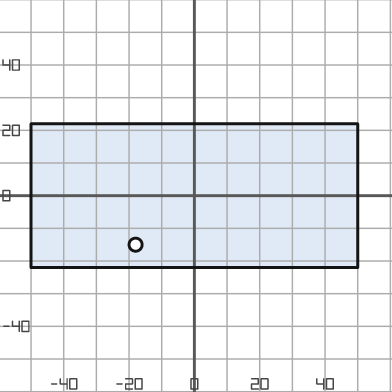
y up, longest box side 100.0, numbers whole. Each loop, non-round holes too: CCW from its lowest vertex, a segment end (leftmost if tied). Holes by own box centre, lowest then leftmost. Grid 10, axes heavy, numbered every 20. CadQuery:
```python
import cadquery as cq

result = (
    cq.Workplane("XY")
    .moveTo(-50.0, -22.0)
    .lineTo(50.0, -22.0)
    .lineTo(50.0, 22.0)
    .lineTo(-50.0, 22.0)
    .close()
    .moveTo(-18.0, -15.0)
    .circle(2.0)
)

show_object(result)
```